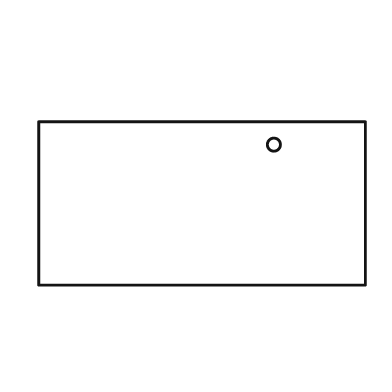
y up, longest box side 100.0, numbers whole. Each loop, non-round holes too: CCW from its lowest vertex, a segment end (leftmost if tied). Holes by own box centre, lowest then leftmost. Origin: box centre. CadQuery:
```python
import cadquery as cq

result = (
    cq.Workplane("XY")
    .moveTo(-50.0, -25.0)
    .lineTo(50.0, -25.0)
    .lineTo(50.0, 25.0)
    .lineTo(-50.0, 25.0)
    .close()
    .moveTo(22.0, 18.0)
    .circle(2.0)
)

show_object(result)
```